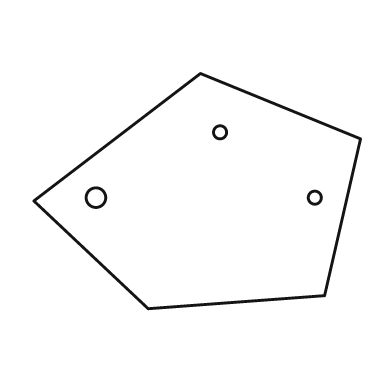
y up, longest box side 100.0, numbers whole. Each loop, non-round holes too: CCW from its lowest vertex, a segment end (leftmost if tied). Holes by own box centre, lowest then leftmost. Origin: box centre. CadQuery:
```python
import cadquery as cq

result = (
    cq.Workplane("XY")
    .moveTo(-15.0, -36.0)
    .lineTo(39.0, -32.0)
    .lineTo(50.0, 16.0)
    .lineTo(1.0, 36.0)
    .lineTo(-50.0, -3.0)
    .close()
    .moveTo(-31.0, -2.0)
    .circle(3.0)
    .moveTo(36.0, -2.0)
    .circle(2.0)
    .moveTo(7.0, 18.0)
    .circle(2.0)
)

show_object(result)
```